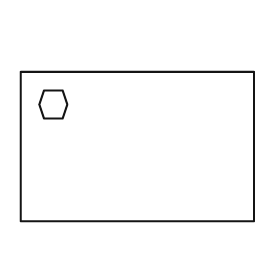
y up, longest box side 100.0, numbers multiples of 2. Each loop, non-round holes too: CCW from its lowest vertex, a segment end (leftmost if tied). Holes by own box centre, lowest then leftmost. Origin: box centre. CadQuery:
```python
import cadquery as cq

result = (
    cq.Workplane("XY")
    .moveTo(-50.0, -32.0)
    .lineTo(50.0, -32.0)
    .lineTo(50.0, 32.0)
    .lineTo(-50.0, 32.0)
    .close()
    .moveTo(-40.0, 12.0)
    .lineTo(-32.0, 12.0)
    .lineTo(-30.0, 18.0)
    .lineTo(-32.0, 24.0)
    .lineTo(-40.0, 24.0)
    .lineTo(-42.0, 18.0)
    .close()
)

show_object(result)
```